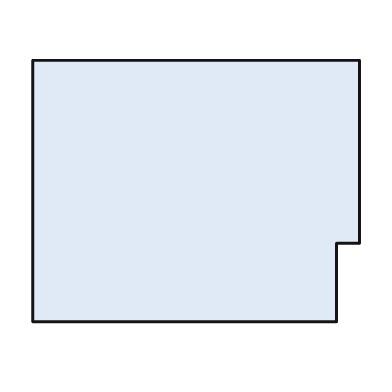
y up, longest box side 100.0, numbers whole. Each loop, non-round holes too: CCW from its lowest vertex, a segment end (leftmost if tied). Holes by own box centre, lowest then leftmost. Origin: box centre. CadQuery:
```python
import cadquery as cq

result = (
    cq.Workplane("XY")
    .moveTo(-50.0, -40.0)
    .lineTo(43.0, -40.0)
    .lineTo(43.0, -16.0)
    .lineTo(50.0, -16.0)
    .lineTo(50.0, 40.0)
    .lineTo(-50.0, 40.0)
    .close()
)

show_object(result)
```